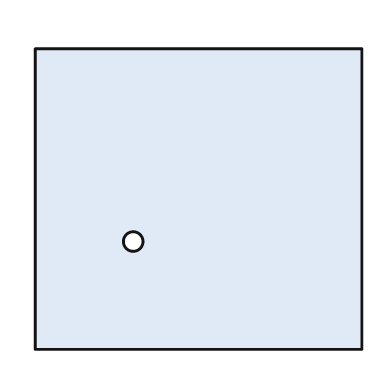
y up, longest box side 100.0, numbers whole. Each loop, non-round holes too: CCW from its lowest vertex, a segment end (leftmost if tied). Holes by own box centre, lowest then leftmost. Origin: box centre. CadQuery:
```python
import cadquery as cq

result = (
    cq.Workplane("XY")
    .moveTo(-50.0, -46.0)
    .lineTo(50.0, -46.0)
    .lineTo(50.0, 46.0)
    .lineTo(-50.0, 46.0)
    .close()
    .moveTo(-20.0, -13.0)
    .circle(3.0)
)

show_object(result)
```